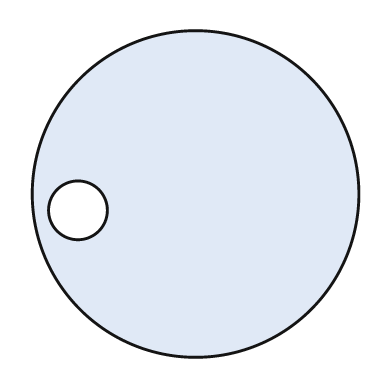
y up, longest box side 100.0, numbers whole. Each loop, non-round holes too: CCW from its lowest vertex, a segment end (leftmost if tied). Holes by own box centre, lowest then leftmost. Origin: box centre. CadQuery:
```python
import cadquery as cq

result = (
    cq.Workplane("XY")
    .moveTo(0.0, 0.0)
    .circle(50.0)
    .moveTo(-36.0, -5.0)
    .circle(9.0)
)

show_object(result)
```